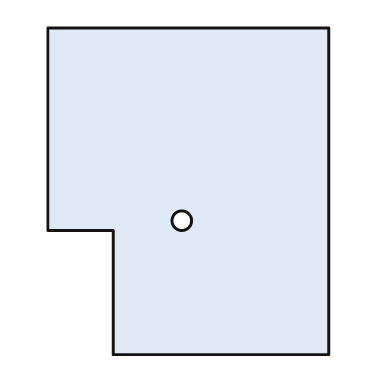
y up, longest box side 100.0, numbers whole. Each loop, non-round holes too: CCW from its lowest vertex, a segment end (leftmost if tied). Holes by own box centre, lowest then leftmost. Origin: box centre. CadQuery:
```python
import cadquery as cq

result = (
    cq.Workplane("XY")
    .moveTo(-23.0, -50.0)
    .lineTo(43.0, -50.0)
    .lineTo(43.0, 50.0)
    .lineTo(-43.0, 50.0)
    .lineTo(-43.0, -12.0)
    .lineTo(-23.0, -12.0)
    .close()
    .moveTo(-2.0, -9.0)
    .circle(3.0)
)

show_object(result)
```